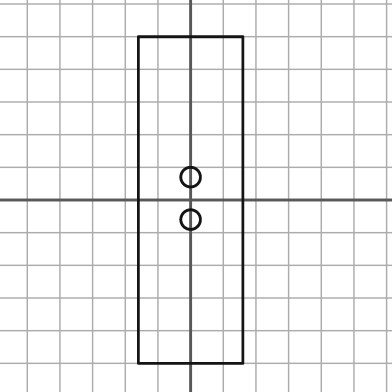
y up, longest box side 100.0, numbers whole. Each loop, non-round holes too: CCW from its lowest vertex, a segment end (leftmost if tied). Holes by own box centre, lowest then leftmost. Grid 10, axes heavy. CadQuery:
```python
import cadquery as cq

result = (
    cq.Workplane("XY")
    .moveTo(-16.0, -50.0)
    .lineTo(16.0, -50.0)
    .lineTo(16.0, 50.0)
    .lineTo(-16.0, 50.0)
    .close()
    .moveTo(0.0, -6.0)
    .circle(3.0)
    .moveTo(0.0, 7.0)
    .circle(3.0)
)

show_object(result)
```